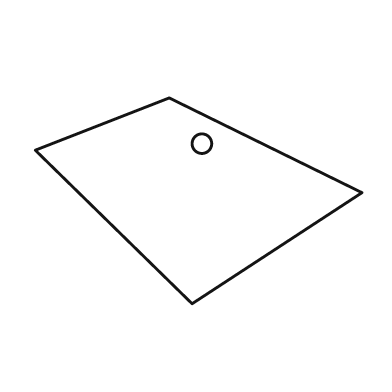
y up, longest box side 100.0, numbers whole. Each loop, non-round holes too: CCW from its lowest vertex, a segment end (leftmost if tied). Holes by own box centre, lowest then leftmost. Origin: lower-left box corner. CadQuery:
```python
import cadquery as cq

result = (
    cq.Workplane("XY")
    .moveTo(48.0, 0.0)
    .lineTo(100.0, 34.0)
    .lineTo(41.0, 63.0)
    .lineTo(0.0, 47.0)
    .close()
    .moveTo(51.0, 49.0)
    .circle(3.0)
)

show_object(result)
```